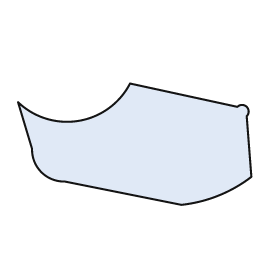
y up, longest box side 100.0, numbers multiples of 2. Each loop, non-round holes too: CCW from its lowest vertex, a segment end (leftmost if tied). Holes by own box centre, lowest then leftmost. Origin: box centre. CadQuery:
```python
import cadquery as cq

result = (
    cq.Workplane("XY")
    .moveTo(20.0, -26.0)
    .threePointArc((36.0, -22.0), (50.0, -14.0))
    .lineTo(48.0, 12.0)
    .threePointArc((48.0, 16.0), (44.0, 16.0))
    .lineTo(-2.0, 26.0)
    .threePointArc((-24.0, 10.0), (-50.0, 18.0))
    .lineTo(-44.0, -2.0)
    .threePointArc((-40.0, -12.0), (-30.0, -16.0))
    .close()
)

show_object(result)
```